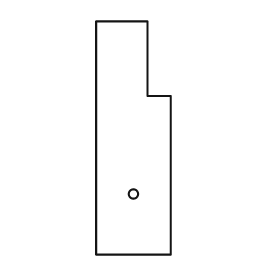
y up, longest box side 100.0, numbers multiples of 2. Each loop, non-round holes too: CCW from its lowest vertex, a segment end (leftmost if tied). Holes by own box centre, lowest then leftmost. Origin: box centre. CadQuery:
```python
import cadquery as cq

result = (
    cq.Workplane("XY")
    .moveTo(-16.0, -50.0)
    .lineTo(16.0, -50.0)
    .lineTo(16.0, 18.0)
    .lineTo(6.0, 18.0)
    .lineTo(6.0, 50.0)
    .lineTo(-16.0, 50.0)
    .close()
    .moveTo(0.0, -24.0)
    .circle(2.0)
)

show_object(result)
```